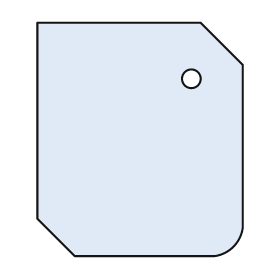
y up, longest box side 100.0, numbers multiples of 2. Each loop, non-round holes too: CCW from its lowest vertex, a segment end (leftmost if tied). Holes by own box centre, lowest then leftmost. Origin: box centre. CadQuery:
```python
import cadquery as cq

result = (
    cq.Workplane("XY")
    .moveTo(-28.0, -50.0)
    .lineTo(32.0, -50.0)
    .threePointArc((40.0, -46.0), (44.0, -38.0))
    .lineTo(44.0, 32.0)
    .lineTo(26.0, 50.0)
    .lineTo(-44.0, 50.0)
    .lineTo(-44.0, -34.0)
    .close()
    .moveTo(22.0, 26.0)
    .circle(4.0)
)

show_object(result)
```